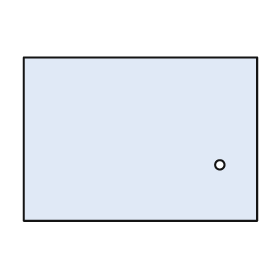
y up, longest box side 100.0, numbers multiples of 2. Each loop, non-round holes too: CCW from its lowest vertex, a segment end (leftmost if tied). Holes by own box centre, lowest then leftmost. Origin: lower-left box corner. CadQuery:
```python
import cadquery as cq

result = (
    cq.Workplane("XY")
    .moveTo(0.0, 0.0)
    .lineTo(100.0, 0.0)
    .lineTo(100.0, 70.0)
    .lineTo(0.0, 70.0)
    .close()
    .moveTo(84.0, 24.0)
    .circle(2.0)
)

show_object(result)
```